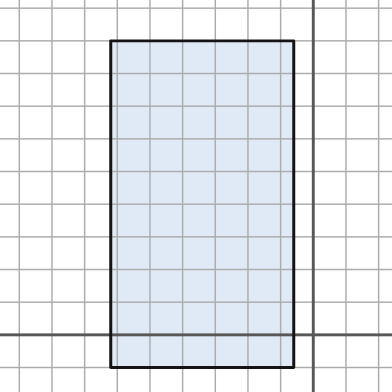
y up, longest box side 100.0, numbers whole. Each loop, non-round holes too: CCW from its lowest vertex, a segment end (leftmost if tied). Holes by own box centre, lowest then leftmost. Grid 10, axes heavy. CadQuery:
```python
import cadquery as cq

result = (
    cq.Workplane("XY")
    .moveTo(-62.0, -10.0)
    .lineTo(-6.0, -10.0)
    .lineTo(-6.0, 90.0)
    .lineTo(-62.0, 90.0)
    .close()
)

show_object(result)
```